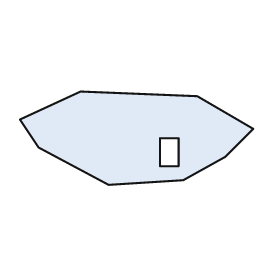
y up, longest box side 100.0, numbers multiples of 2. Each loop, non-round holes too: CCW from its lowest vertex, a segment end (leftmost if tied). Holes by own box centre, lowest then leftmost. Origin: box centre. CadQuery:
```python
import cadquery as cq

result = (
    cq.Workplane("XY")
    .moveTo(-12.0, -20.0)
    .lineTo(20.0, -18.0)
    .lineTo(38.0, -8.0)
    .lineTo(50.0, 4.0)
    .lineTo(26.0, 18.0)
    .lineTo(-24.0, 20.0)
    .lineTo(-50.0, 8.0)
    .lineTo(-42.0, -4.0)
    .close()
    .moveTo(10.0, -12.0)
    .lineTo(18.0, -12.0)
    .lineTo(18.0, 0.0)
    .lineTo(10.0, 0.0)
    .close()
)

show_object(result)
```